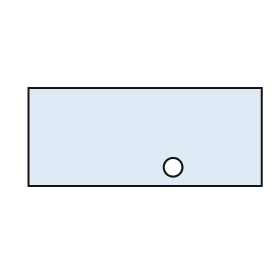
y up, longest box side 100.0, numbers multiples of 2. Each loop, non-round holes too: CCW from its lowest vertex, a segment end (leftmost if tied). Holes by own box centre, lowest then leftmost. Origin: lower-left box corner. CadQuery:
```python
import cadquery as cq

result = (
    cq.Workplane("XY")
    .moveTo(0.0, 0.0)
    .lineTo(100.0, 0.0)
    .lineTo(100.0, 42.0)
    .lineTo(0.0, 42.0)
    .close()
    .moveTo(62.0, 8.0)
    .circle(4.0)
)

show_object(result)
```